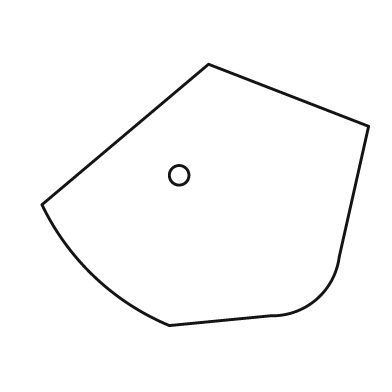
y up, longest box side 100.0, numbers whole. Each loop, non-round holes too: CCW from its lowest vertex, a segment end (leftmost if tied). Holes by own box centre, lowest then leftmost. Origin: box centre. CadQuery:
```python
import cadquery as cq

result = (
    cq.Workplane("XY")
    .moveTo(-11.0, -40.0)
    .lineTo(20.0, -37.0)
    .threePointArc((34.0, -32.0), (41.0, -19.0))
    .lineTo(50.0, 21.0)
    .lineTo(1.0, 40.0)
    .lineTo(-50.0, -3.0)
    .threePointArc((-34.0, -25.0), (-11.0, -40.0))
    .close()
    .moveTo(-8.0, 6.0)
    .circle(3.0)
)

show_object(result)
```